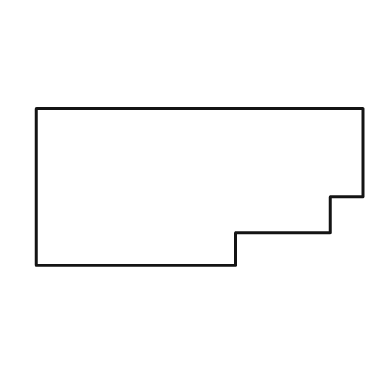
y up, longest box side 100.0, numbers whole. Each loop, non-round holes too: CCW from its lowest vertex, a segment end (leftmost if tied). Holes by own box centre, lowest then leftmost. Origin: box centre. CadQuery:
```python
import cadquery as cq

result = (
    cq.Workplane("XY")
    .moveTo(-50.0, -24.0)
    .lineTo(11.0, -24.0)
    .lineTo(11.0, -14.0)
    .lineTo(40.0, -14.0)
    .lineTo(40.0, -3.0)
    .lineTo(50.0, -3.0)
    .lineTo(50.0, 24.0)
    .lineTo(-50.0, 24.0)
    .close()
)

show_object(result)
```